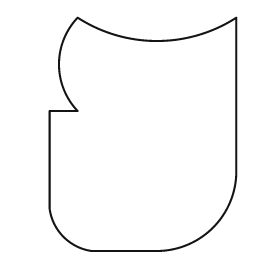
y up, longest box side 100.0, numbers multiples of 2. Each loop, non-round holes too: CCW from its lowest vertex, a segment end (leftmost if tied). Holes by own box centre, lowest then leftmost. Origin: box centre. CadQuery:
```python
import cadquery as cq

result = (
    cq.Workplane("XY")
    .moveTo(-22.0, -50.0)
    .lineTo(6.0, -50.0)
    .threePointArc((30.0, -40.0), (40.0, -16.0))
    .lineTo(40.0, 50.0)
    .threePointArc((6.0, 40.0), (-28.0, 50.0))
    .threePointArc((-36.0, 30.0), (-28.0, 10.0))
    .lineTo(-40.0, 10.0)
    .lineTo(-40.0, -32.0)
    .threePointArc((-34.0, -44.0), (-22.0, -50.0))
    .close()
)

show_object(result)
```